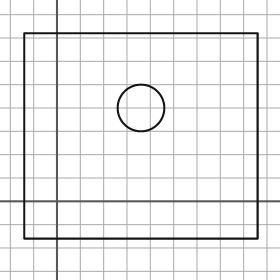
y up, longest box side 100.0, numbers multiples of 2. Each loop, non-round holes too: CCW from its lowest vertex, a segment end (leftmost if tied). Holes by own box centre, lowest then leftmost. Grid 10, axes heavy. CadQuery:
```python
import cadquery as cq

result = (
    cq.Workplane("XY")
    .moveTo(-14.0, -16.0)
    .lineTo(86.0, -16.0)
    .lineTo(86.0, 72.0)
    .lineTo(-14.0, 72.0)
    .close()
    .moveTo(36.0, 40.0)
    .circle(10.0)
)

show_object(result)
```